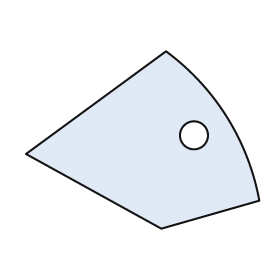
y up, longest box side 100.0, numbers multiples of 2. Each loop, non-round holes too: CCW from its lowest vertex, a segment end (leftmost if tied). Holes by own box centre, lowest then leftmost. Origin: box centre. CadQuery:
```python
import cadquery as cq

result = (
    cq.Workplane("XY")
    .moveTo(8.0, -38.0)
    .lineTo(50.0, -26.0)
    .threePointArc((36.0, 10.0), (10.0, 38.0))
    .lineTo(-50.0, -6.0)
    .close()
    .moveTo(22.0, 2.0)
    .circle(6.0)
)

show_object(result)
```